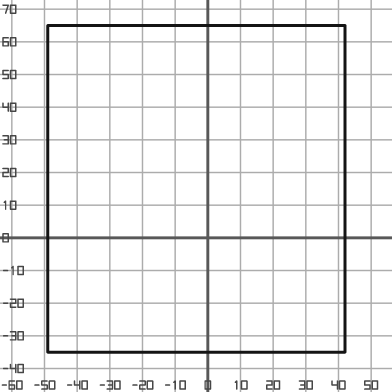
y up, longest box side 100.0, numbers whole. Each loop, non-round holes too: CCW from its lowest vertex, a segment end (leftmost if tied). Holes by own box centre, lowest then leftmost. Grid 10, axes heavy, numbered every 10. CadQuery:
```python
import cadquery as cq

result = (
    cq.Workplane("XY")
    .moveTo(-49.0, -35.0)
    .lineTo(42.0, -35.0)
    .lineTo(42.0, 65.0)
    .lineTo(-49.0, 65.0)
    .close()
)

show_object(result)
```